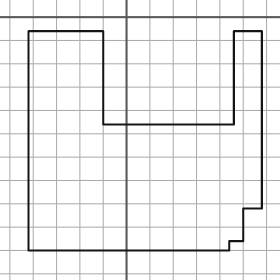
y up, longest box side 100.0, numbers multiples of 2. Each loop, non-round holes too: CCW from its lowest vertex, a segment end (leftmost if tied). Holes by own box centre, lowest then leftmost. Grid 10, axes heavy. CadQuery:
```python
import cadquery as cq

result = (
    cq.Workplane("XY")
    .moveTo(-42.0, -100.0)
    .lineTo(44.0, -100.0)
    .lineTo(44.0, -96.0)
    .lineTo(50.0, -96.0)
    .lineTo(50.0, -82.0)
    .lineTo(58.0, -82.0)
    .lineTo(58.0, -6.0)
    .lineTo(46.0, -6.0)
    .lineTo(46.0, -46.0)
    .lineTo(-10.0, -46.0)
    .lineTo(-10.0, -6.0)
    .lineTo(-42.0, -6.0)
    .close()
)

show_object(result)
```